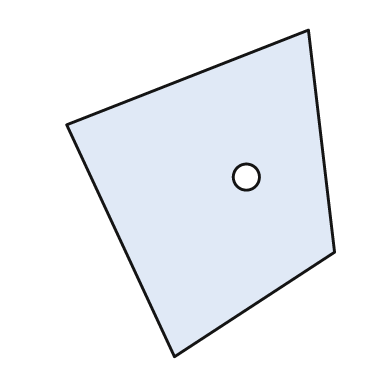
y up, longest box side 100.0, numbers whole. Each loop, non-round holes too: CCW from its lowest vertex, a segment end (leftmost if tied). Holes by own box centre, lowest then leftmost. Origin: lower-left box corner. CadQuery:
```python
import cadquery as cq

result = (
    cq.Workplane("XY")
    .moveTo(33.0, 0.0)
    .lineTo(82.0, 32.0)
    .lineTo(74.0, 100.0)
    .lineTo(0.0, 71.0)
    .close()
    .moveTo(55.0, 55.0)
    .circle(4.0)
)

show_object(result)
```